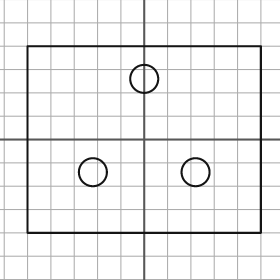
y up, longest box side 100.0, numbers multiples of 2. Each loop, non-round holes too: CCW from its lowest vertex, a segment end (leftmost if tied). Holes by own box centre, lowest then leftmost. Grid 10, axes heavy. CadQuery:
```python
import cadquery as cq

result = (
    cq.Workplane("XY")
    .moveTo(-50.0, -40.0)
    .lineTo(50.0, -40.0)
    .lineTo(50.0, 40.0)
    .lineTo(-50.0, 40.0)
    .close()
    .moveTo(-22.0, -14.0)
    .circle(6.0)
    .moveTo(22.0, -14.0)
    .circle(6.0)
    .moveTo(0.0, 26.0)
    .circle(6.0)
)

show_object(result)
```